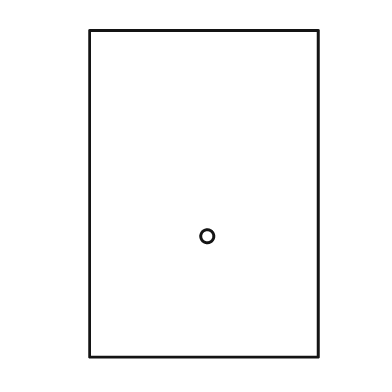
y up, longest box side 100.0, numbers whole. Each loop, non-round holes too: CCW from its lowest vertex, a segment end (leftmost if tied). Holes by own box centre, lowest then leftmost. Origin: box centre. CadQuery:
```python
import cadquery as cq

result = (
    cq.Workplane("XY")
    .moveTo(-35.0, -50.0)
    .lineTo(35.0, -50.0)
    .lineTo(35.0, 50.0)
    .lineTo(-35.0, 50.0)
    .close()
    .moveTo(1.0, -13.0)
    .circle(2.0)
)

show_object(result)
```